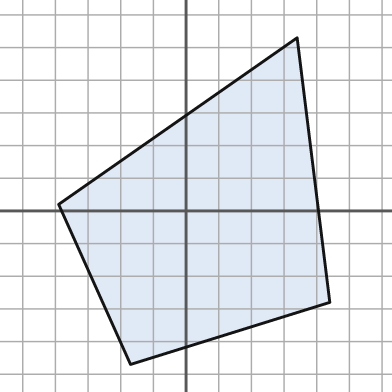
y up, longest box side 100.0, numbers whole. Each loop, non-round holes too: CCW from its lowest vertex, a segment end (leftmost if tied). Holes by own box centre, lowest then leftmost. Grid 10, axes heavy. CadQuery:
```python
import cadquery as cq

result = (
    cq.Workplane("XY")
    .moveTo(-17.0, -47.0)
    .lineTo(44.0, -28.0)
    .lineTo(34.0, 53.0)
    .lineTo(-39.0, 2.0)
    .close()
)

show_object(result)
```